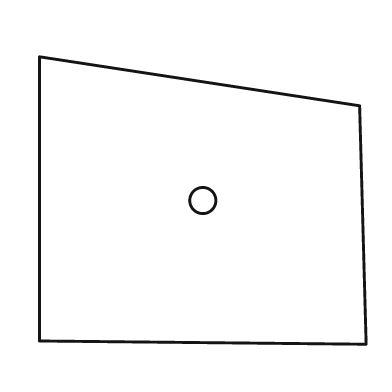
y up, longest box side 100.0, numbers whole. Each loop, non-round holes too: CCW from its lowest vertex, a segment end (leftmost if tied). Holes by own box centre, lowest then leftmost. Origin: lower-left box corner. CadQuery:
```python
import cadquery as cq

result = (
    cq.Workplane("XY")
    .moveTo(100.0, 0.0)
    .lineTo(98.0, 73.0)
    .lineTo(0.0, 88.0)
    .lineTo(0.0, 1.0)
    .close()
    .moveTo(50.0, 44.0)
    .circle(4.0)
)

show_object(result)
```